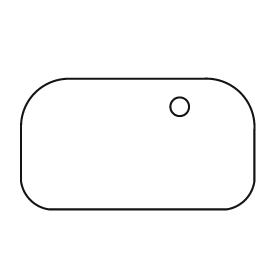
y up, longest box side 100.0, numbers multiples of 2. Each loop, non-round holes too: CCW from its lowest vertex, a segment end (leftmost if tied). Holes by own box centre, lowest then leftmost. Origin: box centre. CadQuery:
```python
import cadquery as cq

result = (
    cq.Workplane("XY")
    .moveTo(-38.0, -28.0)
    .lineTo(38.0, -28.0)
    .threePointArc((46.0, -24.0), (50.0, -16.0))
    .lineTo(50.0, 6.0)
    .threePointArc((44.0, 22.0), (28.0, 28.0))
    .lineTo(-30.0, 28.0)
    .threePointArc((-44.0, 22.0), (-50.0, 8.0))
    .lineTo(-50.0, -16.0)
    .threePointArc((-46.0, -24.0), (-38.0, -28.0))
    .close()
    .moveTo(18.0, 16.0)
    .circle(4.0)
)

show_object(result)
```